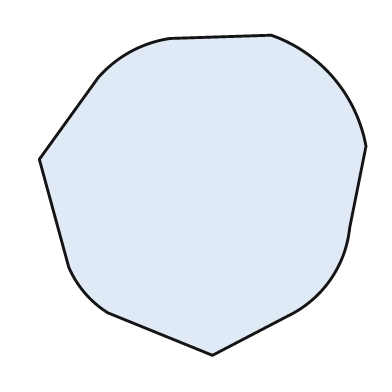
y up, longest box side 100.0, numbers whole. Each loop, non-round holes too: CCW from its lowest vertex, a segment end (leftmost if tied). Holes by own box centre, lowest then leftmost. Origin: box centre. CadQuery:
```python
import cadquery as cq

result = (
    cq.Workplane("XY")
    .moveTo(3.0, -49.0)
    .lineTo(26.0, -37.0)
    .threePointArc((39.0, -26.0), (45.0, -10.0))
    .lineTo(50.0, 15.0)
    .threePointArc((40.0, 36.0), (21.0, 49.0))
    .lineTo(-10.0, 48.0)
    .threePointArc((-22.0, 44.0), (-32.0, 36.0))
    .lineTo(-50.0, 11.0)
    .lineTo(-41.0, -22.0)
    .threePointArc((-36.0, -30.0), (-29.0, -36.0))
    .close()
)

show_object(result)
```